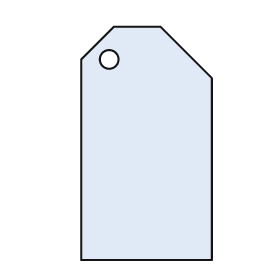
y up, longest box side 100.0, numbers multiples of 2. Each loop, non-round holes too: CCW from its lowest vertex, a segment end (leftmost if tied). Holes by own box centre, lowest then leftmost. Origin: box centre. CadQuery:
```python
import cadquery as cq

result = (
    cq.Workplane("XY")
    .moveTo(-28.0, -50.0)
    .lineTo(28.0, -50.0)
    .lineTo(28.0, 28.0)
    .lineTo(6.0, 50.0)
    .lineTo(-14.0, 50.0)
    .lineTo(-28.0, 36.0)
    .close()
    .moveTo(-16.0, 36.0)
    .circle(4.0)
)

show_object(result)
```